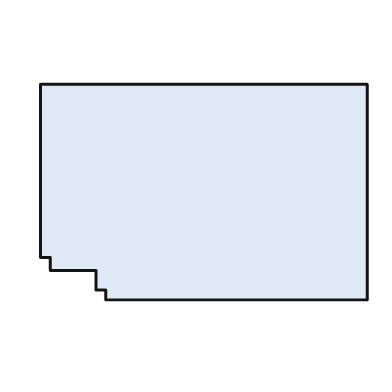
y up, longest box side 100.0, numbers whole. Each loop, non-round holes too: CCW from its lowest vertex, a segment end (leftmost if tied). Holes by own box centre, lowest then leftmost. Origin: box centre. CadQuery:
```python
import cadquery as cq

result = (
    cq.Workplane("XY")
    .moveTo(-30.0, -33.0)
    .lineTo(50.0, -33.0)
    .lineTo(50.0, 33.0)
    .lineTo(-50.0, 33.0)
    .lineTo(-50.0, -20.0)
    .lineTo(-47.0, -20.0)
    .lineTo(-47.0, -24.0)
    .lineTo(-33.0, -24.0)
    .lineTo(-33.0, -30.0)
    .lineTo(-30.0, -30.0)
    .close()
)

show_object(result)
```